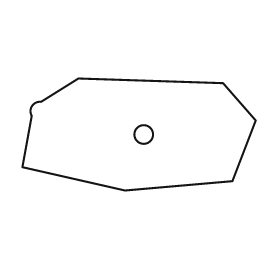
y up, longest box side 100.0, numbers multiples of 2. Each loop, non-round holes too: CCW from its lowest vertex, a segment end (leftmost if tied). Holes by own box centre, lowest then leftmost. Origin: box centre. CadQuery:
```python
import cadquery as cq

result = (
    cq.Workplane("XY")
    .moveTo(-6.0, -24.0)
    .lineTo(40.0, -20.0)
    .lineTo(50.0, 6.0)
    .lineTo(36.0, 22.0)
    .lineTo(-26.0, 24.0)
    .lineTo(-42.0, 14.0)
    .threePointArc((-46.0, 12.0), (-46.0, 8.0))
    .lineTo(-50.0, -14.0)
    .close()
    .moveTo(2.0, 0.0)
    .circle(4.0)
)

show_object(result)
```